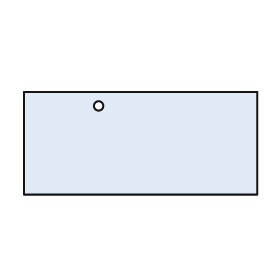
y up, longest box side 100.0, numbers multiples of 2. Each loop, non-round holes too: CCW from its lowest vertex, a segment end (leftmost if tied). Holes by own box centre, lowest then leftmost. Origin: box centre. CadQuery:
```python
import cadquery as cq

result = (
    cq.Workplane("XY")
    .moveTo(-50.0, -22.0)
    .lineTo(50.0, -22.0)
    .lineTo(50.0, 22.0)
    .lineTo(-50.0, 22.0)
    .close()
    .moveTo(-18.0, 16.0)
    .circle(2.0)
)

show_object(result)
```